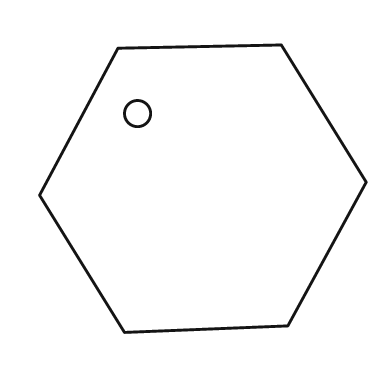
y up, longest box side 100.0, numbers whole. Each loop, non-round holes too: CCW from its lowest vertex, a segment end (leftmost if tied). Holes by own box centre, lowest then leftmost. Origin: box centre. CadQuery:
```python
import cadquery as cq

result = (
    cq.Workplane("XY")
    .moveTo(-24.0, -44.0)
    .lineTo(26.0, -42.0)
    .lineTo(50.0, 2.0)
    .lineTo(24.0, 44.0)
    .lineTo(-26.0, 43.0)
    .lineTo(-50.0, -2.0)
    .close()
    .moveTo(-20.0, 23.0)
    .circle(4.0)
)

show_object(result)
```